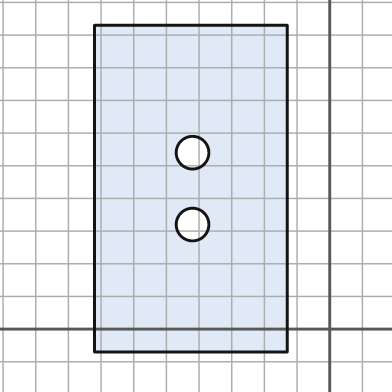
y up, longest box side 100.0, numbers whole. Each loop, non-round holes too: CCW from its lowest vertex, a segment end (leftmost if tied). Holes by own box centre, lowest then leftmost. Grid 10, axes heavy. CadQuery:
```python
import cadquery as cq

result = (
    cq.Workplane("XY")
    .moveTo(-72.0, -7.0)
    .lineTo(-13.0, -7.0)
    .lineTo(-13.0, 93.0)
    .lineTo(-72.0, 93.0)
    .close()
    .moveTo(-42.0, 32.0)
    .circle(5.0)
    .moveTo(-42.0, 54.0)
    .circle(5.0)
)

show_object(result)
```